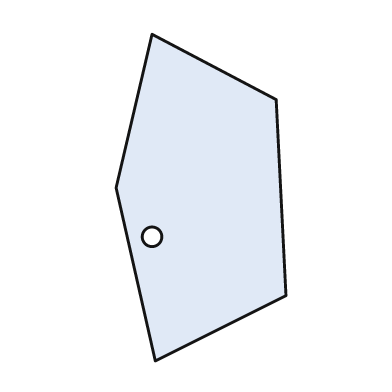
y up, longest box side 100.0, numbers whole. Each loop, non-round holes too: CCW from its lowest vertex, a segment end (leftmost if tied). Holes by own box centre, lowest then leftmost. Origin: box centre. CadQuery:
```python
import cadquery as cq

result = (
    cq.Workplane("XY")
    .moveTo(-14.0, -50.0)
    .lineTo(26.0, -30.0)
    .lineTo(23.0, 30.0)
    .lineTo(-15.0, 50.0)
    .lineTo(-26.0, 3.0)
    .close()
    .moveTo(-15.0, -12.0)
    .circle(3.0)
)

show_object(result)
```